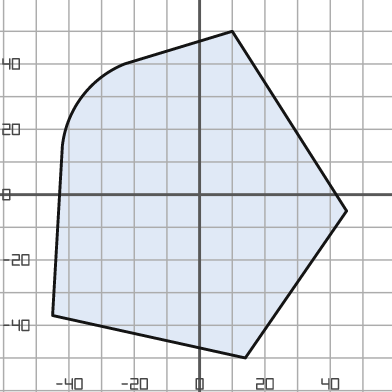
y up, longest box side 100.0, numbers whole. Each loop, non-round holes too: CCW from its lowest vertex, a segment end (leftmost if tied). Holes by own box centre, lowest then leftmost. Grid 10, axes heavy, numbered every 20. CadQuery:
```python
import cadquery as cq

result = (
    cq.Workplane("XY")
    .moveTo(14.0, -50.0)
    .lineTo(45.0, -5.0)
    .lineTo(10.0, 50.0)
    .lineTo(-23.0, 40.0)
    .threePointArc((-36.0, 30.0), (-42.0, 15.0))
    .lineTo(-45.0, -37.0)
    .close()
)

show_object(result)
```